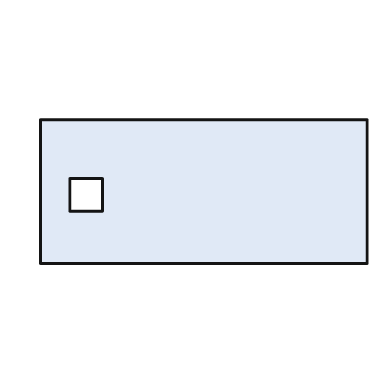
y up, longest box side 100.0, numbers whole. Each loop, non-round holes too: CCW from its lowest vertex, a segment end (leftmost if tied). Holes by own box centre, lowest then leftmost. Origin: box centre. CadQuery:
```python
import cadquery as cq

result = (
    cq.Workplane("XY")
    .moveTo(-50.0, -22.0)
    .lineTo(50.0, -22.0)
    .lineTo(50.0, 22.0)
    .lineTo(-50.0, 22.0)
    .close()
    .moveTo(-41.0, -6.0)
    .lineTo(-31.0, -6.0)
    .lineTo(-31.0, 4.0)
    .lineTo(-41.0, 4.0)
    .close()
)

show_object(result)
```